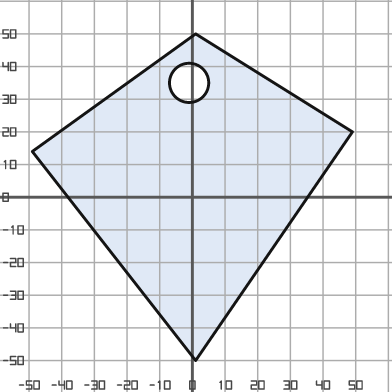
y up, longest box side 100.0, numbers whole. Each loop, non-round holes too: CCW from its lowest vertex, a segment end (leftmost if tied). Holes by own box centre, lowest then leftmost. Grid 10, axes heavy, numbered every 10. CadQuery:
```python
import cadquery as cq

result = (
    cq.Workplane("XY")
    .moveTo(1.0, -50.0)
    .lineTo(49.0, 20.0)
    .lineTo(1.0, 50.0)
    .lineTo(-49.0, 14.0)
    .close()
    .moveTo(-1.0, 35.0)
    .circle(6.0)
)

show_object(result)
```